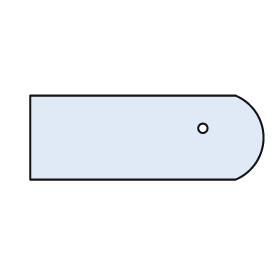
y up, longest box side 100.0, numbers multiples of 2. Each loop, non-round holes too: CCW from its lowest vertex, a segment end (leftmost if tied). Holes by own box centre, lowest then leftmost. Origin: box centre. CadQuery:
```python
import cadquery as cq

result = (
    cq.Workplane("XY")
    .moveTo(-50.0, -18.0)
    .lineTo(38.0, -18.0)
    .threePointArc((50.0, 0.0), (38.0, 18.0))
    .lineTo(-50.0, 18.0)
    .close()
    .moveTo(24.0, 4.0)
    .circle(2.0)
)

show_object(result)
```